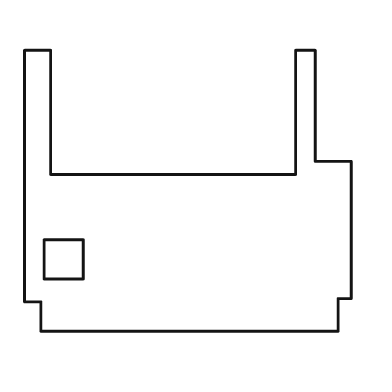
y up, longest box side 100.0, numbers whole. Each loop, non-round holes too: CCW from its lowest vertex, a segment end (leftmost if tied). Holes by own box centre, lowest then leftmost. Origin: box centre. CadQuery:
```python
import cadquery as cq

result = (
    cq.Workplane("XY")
    .moveTo(-45.0, -43.0)
    .lineTo(46.0, -43.0)
    .lineTo(46.0, -33.0)
    .lineTo(50.0, -33.0)
    .lineTo(50.0, 9.0)
    .lineTo(39.0, 9.0)
    .lineTo(39.0, 43.0)
    .lineTo(33.0, 43.0)
    .lineTo(33.0, 5.0)
    .lineTo(-42.0, 5.0)
    .lineTo(-42.0, 43.0)
    .lineTo(-50.0, 43.0)
    .lineTo(-50.0, -34.0)
    .lineTo(-45.0, -34.0)
    .close()
    .moveTo(-44.0, -27.0)
    .lineTo(-32.0, -27.0)
    .lineTo(-32.0, -15.0)
    .lineTo(-44.0, -15.0)
    .close()
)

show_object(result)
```